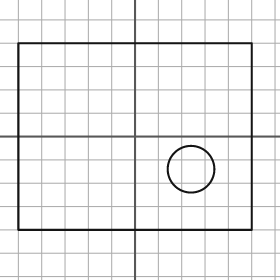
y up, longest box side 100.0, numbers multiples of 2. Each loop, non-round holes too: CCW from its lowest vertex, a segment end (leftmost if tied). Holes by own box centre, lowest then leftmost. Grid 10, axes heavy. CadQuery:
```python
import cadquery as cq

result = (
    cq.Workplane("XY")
    .moveTo(-50.0, -40.0)
    .lineTo(50.0, -40.0)
    .lineTo(50.0, 40.0)
    .lineTo(-50.0, 40.0)
    .close()
    .moveTo(24.0, -14.0)
    .circle(10.0)
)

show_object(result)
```